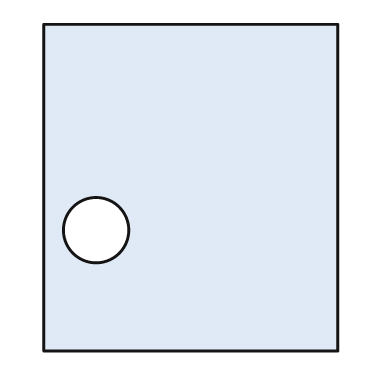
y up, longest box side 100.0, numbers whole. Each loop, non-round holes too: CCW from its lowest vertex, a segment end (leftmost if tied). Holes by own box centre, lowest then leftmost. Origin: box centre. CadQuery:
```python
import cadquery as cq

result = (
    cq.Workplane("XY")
    .moveTo(-45.0, -50.0)
    .lineTo(45.0, -50.0)
    .lineTo(45.0, 50.0)
    .lineTo(-45.0, 50.0)
    .close()
    .moveTo(-29.0, -13.0)
    .circle(10.0)
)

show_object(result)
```